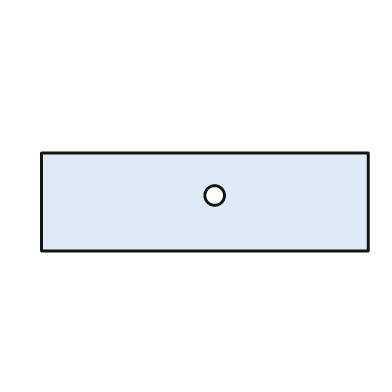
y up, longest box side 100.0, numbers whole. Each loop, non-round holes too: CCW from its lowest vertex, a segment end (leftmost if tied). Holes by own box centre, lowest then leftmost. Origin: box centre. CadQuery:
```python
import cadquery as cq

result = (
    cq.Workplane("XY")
    .moveTo(-50.0, -15.0)
    .lineTo(50.0, -15.0)
    .lineTo(50.0, 15.0)
    .lineTo(-50.0, 15.0)
    .close()
    .moveTo(3.0, 2.0)
    .circle(3.0)
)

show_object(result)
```